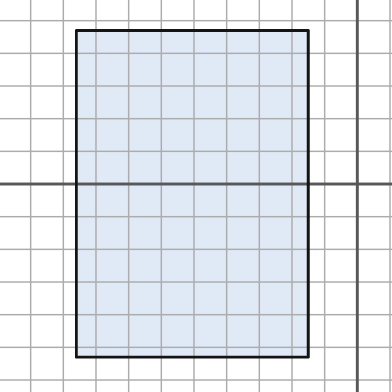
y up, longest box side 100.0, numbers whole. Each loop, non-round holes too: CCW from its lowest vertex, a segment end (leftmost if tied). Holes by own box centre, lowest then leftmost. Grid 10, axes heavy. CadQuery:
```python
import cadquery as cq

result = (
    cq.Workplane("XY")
    .moveTo(-86.0, -53.0)
    .lineTo(-15.0, -53.0)
    .lineTo(-15.0, 47.0)
    .lineTo(-86.0, 47.0)
    .close()
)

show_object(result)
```